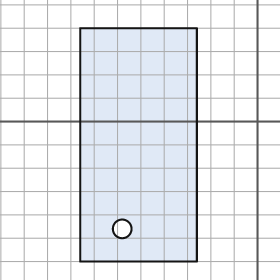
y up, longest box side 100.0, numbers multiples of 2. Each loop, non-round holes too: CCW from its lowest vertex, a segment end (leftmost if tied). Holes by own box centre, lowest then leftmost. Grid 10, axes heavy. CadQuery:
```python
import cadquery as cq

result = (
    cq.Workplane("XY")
    .moveTo(-76.0, -60.0)
    .lineTo(-26.0, -60.0)
    .lineTo(-26.0, 40.0)
    .lineTo(-76.0, 40.0)
    .close()
    .moveTo(-58.0, -46.0)
    .circle(4.0)
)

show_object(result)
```